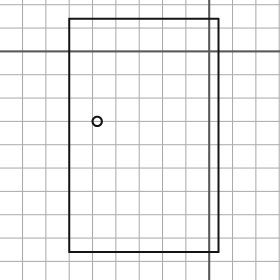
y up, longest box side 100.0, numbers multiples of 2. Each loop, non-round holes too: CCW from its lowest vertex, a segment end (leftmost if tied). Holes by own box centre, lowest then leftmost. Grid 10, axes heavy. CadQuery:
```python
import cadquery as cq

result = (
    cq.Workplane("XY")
    .moveTo(-60.0, -86.0)
    .lineTo(4.0, -86.0)
    .lineTo(4.0, 14.0)
    .lineTo(-60.0, 14.0)
    .close()
    .moveTo(-48.0, -30.0)
    .circle(2.0)
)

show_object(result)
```